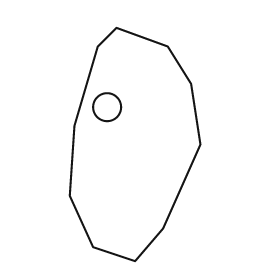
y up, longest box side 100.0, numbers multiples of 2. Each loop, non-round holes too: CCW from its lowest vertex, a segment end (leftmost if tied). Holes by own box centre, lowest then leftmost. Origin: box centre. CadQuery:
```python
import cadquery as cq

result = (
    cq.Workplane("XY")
    .moveTo(0.0, -50.0)
    .lineTo(12.0, -36.0)
    .lineTo(28.0, 0.0)
    .lineTo(24.0, 26.0)
    .lineTo(14.0, 42.0)
    .lineTo(-8.0, 50.0)
    .lineTo(-16.0, 42.0)
    .lineTo(-26.0, 8.0)
    .lineTo(-28.0, -22.0)
    .lineTo(-18.0, -44.0)
    .close()
    .moveTo(-12.0, 16.0)
    .circle(6.0)
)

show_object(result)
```